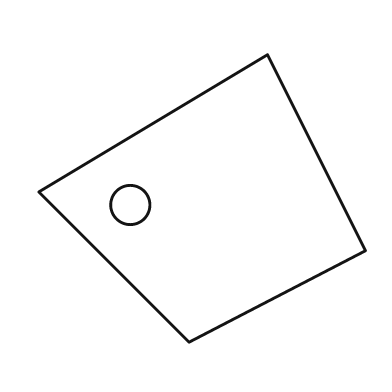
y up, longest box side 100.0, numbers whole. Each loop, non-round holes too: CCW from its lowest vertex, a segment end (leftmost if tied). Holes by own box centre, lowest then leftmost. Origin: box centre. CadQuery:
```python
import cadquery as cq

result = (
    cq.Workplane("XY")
    .moveTo(-4.0, -44.0)
    .lineTo(50.0, -16.0)
    .lineTo(20.0, 44.0)
    .lineTo(-50.0, 2.0)
    .close()
    .moveTo(-22.0, -2.0)
    .circle(6.0)
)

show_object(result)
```